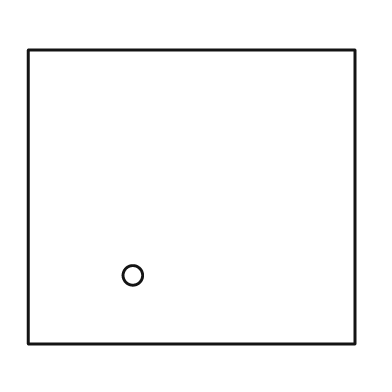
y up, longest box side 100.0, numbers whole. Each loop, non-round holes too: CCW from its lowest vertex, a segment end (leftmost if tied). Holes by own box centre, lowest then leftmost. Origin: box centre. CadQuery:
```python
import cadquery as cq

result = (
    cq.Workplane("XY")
    .moveTo(-50.0, -45.0)
    .lineTo(50.0, -45.0)
    .lineTo(50.0, 45.0)
    .lineTo(-50.0, 45.0)
    .close()
    .moveTo(-18.0, -24.0)
    .circle(3.0)
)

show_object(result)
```